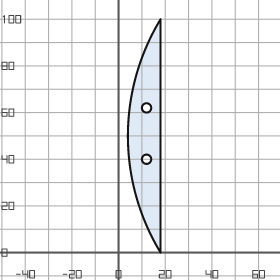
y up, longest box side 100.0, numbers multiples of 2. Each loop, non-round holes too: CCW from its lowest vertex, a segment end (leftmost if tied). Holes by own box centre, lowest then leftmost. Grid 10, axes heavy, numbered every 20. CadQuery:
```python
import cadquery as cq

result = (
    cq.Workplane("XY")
    .moveTo(18.0, 0.0)
    .lineTo(18.0, 100.0)
    .threePointArc((4.0, 50.0), (18.0, 0.0))
    .close()
    .moveTo(12.0, 40.0)
    .circle(2.0)
    .moveTo(12.0, 62.0)
    .circle(2.0)
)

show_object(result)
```